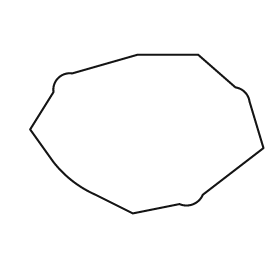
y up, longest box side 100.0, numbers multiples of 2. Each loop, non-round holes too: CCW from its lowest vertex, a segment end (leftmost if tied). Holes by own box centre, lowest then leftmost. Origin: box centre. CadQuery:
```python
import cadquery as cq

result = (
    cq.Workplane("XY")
    .moveTo(-6.0, -34.0)
    .lineTo(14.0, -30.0)
    .threePointArc((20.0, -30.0), (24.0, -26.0))
    .lineTo(50.0, -6.0)
    .lineTo(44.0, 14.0)
    .threePointArc((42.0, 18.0), (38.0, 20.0))
    .lineTo(22.0, 34.0)
    .lineTo(-4.0, 34.0)
    .lineTo(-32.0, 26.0)
    .threePointArc((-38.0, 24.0), (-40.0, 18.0))
    .lineTo(-50.0, 2.0)
    .lineTo(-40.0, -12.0)
    .threePointArc((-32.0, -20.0), (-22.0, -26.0))
    .close()
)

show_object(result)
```